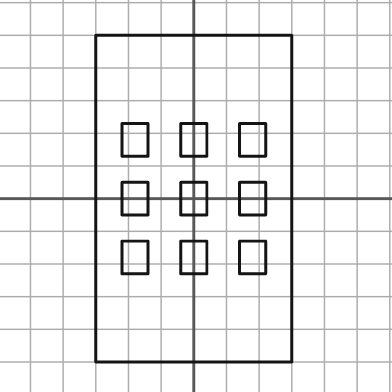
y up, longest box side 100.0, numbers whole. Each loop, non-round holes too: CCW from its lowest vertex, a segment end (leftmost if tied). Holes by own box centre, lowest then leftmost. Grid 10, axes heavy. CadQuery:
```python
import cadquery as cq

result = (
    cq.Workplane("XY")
    .moveTo(-30.0, -50.0)
    .lineTo(30.0, -50.0)
    .lineTo(30.0, 50.0)
    .lineTo(-30.0, 50.0)
    .close()
    .moveTo(-22.0, -23.0)
    .lineTo(-14.0, -23.0)
    .lineTo(-14.0, -13.0)
    .lineTo(-22.0, -13.0)
    .close()
    .moveTo(-4.0, -23.0)
    .lineTo(4.0, -23.0)
    .lineTo(4.0, -13.0)
    .lineTo(-4.0, -13.0)
    .close()
    .moveTo(14.0, -23.0)
    .lineTo(22.0, -23.0)
    .lineTo(22.0, -13.0)
    .lineTo(14.0, -13.0)
    .close()
    .moveTo(-22.0, -5.0)
    .lineTo(-14.0, -5.0)
    .lineTo(-14.0, 5.0)
    .lineTo(-22.0, 5.0)
    .close()
    .moveTo(-4.0, -5.0)
    .lineTo(4.0, -5.0)
    .lineTo(4.0, 5.0)
    .lineTo(-4.0, 5.0)
    .close()
    .moveTo(14.0, -5.0)
    .lineTo(22.0, -5.0)
    .lineTo(22.0, 5.0)
    .lineTo(14.0, 5.0)
    .close()
    .moveTo(-22.0, 13.0)
    .lineTo(-14.0, 13.0)
    .lineTo(-14.0, 23.0)
    .lineTo(-22.0, 23.0)
    .close()
    .moveTo(-4.0, 13.0)
    .lineTo(4.0, 13.0)
    .lineTo(4.0, 23.0)
    .lineTo(-4.0, 23.0)
    .close()
    .moveTo(14.0, 13.0)
    .lineTo(22.0, 13.0)
    .lineTo(22.0, 23.0)
    .lineTo(14.0, 23.0)
    .close()
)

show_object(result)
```